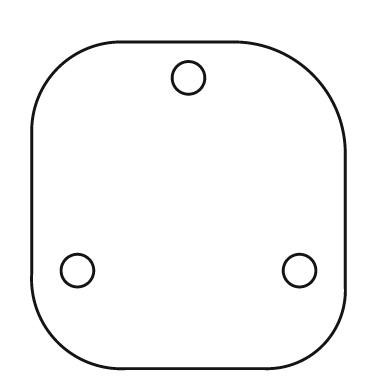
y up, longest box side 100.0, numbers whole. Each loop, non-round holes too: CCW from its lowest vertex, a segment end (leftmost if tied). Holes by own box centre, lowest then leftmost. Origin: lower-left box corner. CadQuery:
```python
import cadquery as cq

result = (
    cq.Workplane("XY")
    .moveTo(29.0, 0.0)
    .lineTo(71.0, 0.0)
    .threePointArc((89.0, 7.0), (96.0, 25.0))
    .lineTo(96.0, 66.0)
    .threePointArc((86.0, 90.0), (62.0, 100.0))
    .lineTo(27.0, 100.0)
    .threePointArc((8.0, 92.0), (0.0, 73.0))
    .lineTo(0.0, 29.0)
    .threePointArc((8.0, 8.0), (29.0, 0.0))
    .close()
    .moveTo(14.0, 30.0)
    .circle(5.0)
    .moveTo(82.0, 30.0)
    .circle(5.0)
    .moveTo(48.0, 89.0)
    .circle(5.0)
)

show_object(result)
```